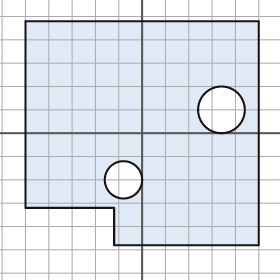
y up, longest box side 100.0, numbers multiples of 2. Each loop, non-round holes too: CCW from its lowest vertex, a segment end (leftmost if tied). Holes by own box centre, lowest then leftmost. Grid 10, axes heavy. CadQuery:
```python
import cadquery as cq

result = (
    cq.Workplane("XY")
    .moveTo(-12.0, -48.0)
    .lineTo(50.0, -48.0)
    .lineTo(50.0, 48.0)
    .lineTo(-50.0, 48.0)
    .lineTo(-50.0, -32.0)
    .lineTo(-12.0, -32.0)
    .close()
    .moveTo(-8.0, -20.0)
    .circle(8.0)
    .moveTo(34.0, 10.0)
    .circle(10.0)
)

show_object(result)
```